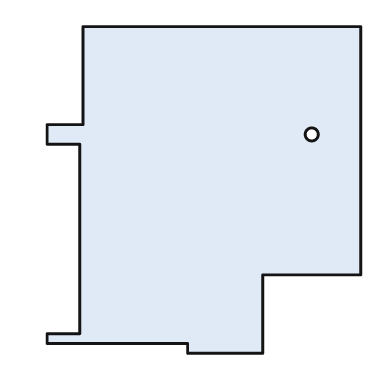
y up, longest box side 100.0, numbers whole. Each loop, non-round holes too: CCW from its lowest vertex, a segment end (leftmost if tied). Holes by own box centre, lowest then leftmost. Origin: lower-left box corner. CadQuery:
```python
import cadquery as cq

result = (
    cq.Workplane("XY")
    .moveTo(43.0, 0.0)
    .lineTo(66.0, 0.0)
    .lineTo(66.0, 24.0)
    .lineTo(96.0, 24.0)
    .lineTo(96.0, 100.0)
    .lineTo(11.0, 100.0)
    .lineTo(11.0, 70.0)
    .lineTo(0.0, 70.0)
    .lineTo(0.0, 64.0)
    .lineTo(10.0, 64.0)
    .lineTo(10.0, 6.0)
    .lineTo(0.0, 6.0)
    .lineTo(0.0, 3.0)
    .lineTo(43.0, 3.0)
    .close()
    .moveTo(81.0, 67.0)
    .circle(2.0)
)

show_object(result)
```